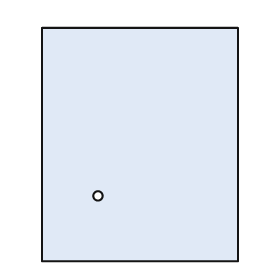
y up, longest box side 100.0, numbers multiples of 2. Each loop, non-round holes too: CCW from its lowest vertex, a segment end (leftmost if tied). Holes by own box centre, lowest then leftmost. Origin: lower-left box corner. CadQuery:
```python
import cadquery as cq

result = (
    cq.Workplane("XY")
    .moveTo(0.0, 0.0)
    .lineTo(84.0, 0.0)
    .lineTo(84.0, 100.0)
    .lineTo(0.0, 100.0)
    .close()
    .moveTo(24.0, 28.0)
    .circle(2.0)
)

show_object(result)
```